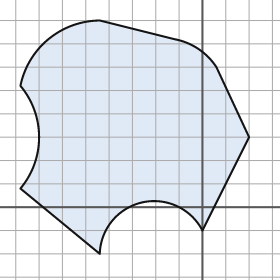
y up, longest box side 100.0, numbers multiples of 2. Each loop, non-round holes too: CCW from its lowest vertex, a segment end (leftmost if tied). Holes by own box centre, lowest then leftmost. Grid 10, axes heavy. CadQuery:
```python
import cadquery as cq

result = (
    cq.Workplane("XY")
    .moveTo(-44.0, -20.0)
    .threePointArc((-26.0, 2.0), (0.0, -10.0))
    .lineTo(20.0, 30.0)
    .lineTo(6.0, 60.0)
    .threePointArc((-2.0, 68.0), (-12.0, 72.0))
    .lineTo(-44.0, 80.0)
    .threePointArc((-66.0, 72.0), (-78.0, 52.0))
    .threePointArc((-70.0, 30.0), (-78.0, 8.0))
    .close()
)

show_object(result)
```